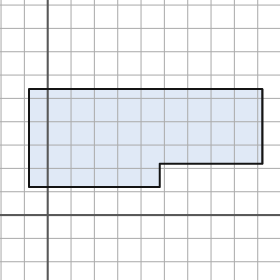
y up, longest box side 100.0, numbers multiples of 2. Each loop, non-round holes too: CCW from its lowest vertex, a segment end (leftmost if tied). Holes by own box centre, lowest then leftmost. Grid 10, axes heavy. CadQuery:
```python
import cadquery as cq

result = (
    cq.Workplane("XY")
    .moveTo(-8.0, 12.0)
    .lineTo(48.0, 12.0)
    .lineTo(48.0, 22.0)
    .lineTo(92.0, 22.0)
    .lineTo(92.0, 54.0)
    .lineTo(-8.0, 54.0)
    .close()
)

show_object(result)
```